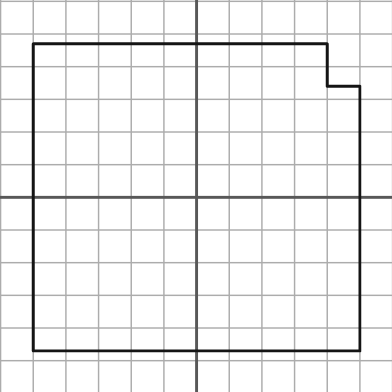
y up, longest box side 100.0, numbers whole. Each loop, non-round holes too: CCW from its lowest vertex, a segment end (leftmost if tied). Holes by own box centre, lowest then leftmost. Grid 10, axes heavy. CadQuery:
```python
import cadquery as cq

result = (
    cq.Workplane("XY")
    .moveTo(-50.0, -47.0)
    .lineTo(50.0, -47.0)
    .lineTo(50.0, 34.0)
    .lineTo(40.0, 34.0)
    .lineTo(40.0, 47.0)
    .lineTo(-50.0, 47.0)
    .close()
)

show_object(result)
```